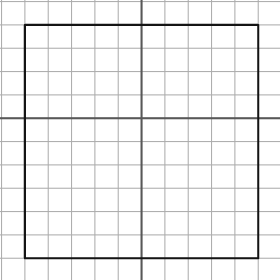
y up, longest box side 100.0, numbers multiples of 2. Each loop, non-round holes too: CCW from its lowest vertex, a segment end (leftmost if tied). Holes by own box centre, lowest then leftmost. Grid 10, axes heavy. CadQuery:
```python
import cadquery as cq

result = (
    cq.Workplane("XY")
    .moveTo(-50.0, -60.0)
    .lineTo(50.0, -60.0)
    .lineTo(50.0, 40.0)
    .lineTo(-50.0, 40.0)
    .close()
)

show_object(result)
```